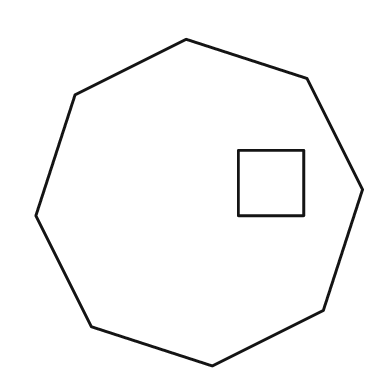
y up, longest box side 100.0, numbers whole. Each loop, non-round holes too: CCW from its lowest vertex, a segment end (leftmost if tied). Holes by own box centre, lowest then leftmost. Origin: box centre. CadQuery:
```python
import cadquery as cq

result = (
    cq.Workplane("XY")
    .moveTo(4.0, -50.0)
    .lineTo(38.0, -33.0)
    .lineTo(50.0, 4.0)
    .lineTo(33.0, 38.0)
    .lineTo(-4.0, 50.0)
    .lineTo(-38.0, 33.0)
    .lineTo(-50.0, -4.0)
    .lineTo(-33.0, -38.0)
    .close()
    .moveTo(12.0, -4.0)
    .lineTo(32.0, -4.0)
    .lineTo(32.0, 16.0)
    .lineTo(12.0, 16.0)
    .close()
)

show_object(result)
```